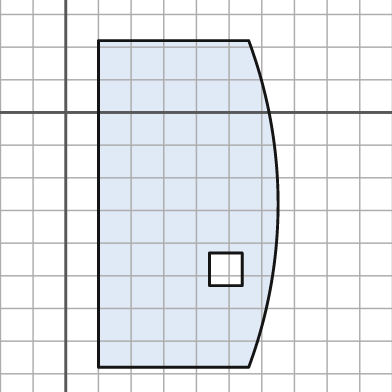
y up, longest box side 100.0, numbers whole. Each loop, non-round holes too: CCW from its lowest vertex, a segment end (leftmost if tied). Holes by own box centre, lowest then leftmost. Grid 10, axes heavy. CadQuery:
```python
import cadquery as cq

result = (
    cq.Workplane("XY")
    .moveTo(10.0, -78.0)
    .lineTo(56.0, -78.0)
    .threePointArc((65.0, -28.0), (56.0, 22.0))
    .lineTo(10.0, 22.0)
    .close()
    .moveTo(44.0, -53.0)
    .lineTo(54.0, -53.0)
    .lineTo(54.0, -43.0)
    .lineTo(44.0, -43.0)
    .close()
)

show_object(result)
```